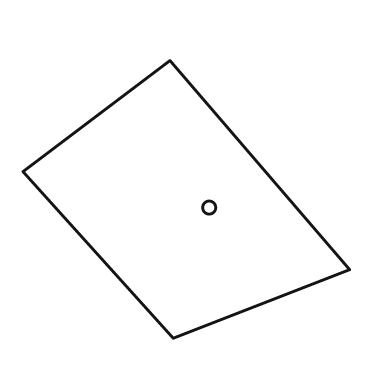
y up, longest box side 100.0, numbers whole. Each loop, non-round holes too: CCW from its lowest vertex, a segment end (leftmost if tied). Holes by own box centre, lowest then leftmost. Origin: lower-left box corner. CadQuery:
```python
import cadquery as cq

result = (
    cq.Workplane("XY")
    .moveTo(46.0, 0.0)
    .lineTo(100.0, 21.0)
    .lineTo(45.0, 85.0)
    .lineTo(0.0, 51.0)
    .close()
    .moveTo(57.0, 40.0)
    .circle(2.0)
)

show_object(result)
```